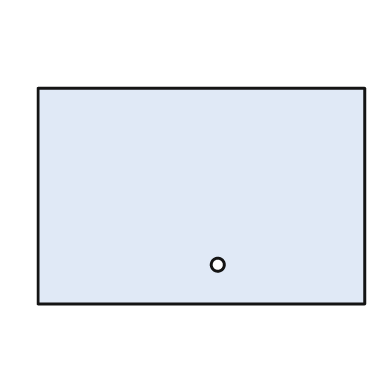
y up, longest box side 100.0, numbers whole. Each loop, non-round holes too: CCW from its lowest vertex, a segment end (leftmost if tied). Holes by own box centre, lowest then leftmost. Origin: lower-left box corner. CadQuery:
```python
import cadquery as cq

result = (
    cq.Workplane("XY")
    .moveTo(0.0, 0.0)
    .lineTo(100.0, 0.0)
    .lineTo(100.0, 66.0)
    .lineTo(0.0, 66.0)
    .close()
    .moveTo(55.0, 12.0)
    .circle(2.0)
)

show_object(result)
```